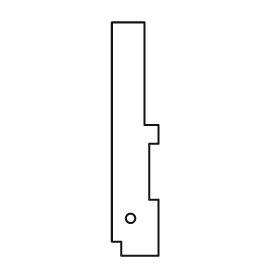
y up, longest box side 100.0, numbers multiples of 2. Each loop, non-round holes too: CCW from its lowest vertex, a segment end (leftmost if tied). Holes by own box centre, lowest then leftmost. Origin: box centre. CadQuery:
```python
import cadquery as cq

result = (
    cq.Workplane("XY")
    .moveTo(-6.0, -50.0)
    .lineTo(10.0, -50.0)
    .lineTo(10.0, -26.0)
    .lineTo(6.0, -26.0)
    .lineTo(6.0, -2.0)
    .lineTo(10.0, -2.0)
    .lineTo(10.0, 6.0)
    .lineTo(4.0, 6.0)
    .lineTo(4.0, 50.0)
    .lineTo(-10.0, 50.0)
    .lineTo(-10.0, -44.0)
    .lineTo(-6.0, -44.0)
    .close()
    .moveTo(-2.0, -34.0)
    .circle(2.0)
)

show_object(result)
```